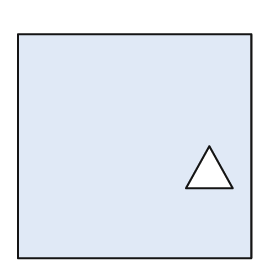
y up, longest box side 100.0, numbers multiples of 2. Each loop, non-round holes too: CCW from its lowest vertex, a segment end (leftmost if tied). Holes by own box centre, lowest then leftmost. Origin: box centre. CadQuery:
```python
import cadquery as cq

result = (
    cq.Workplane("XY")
    .moveTo(-50.0, -48.0)
    .lineTo(50.0, -48.0)
    .lineTo(50.0, 48.0)
    .lineTo(-50.0, 48.0)
    .close()
    .moveTo(22.0, -18.0)
    .lineTo(42.0, -18.0)
    .lineTo(32.0, 0.0)
    .close()
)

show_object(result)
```